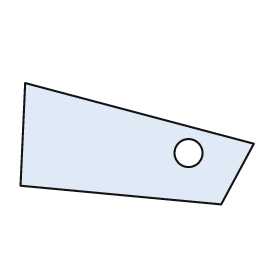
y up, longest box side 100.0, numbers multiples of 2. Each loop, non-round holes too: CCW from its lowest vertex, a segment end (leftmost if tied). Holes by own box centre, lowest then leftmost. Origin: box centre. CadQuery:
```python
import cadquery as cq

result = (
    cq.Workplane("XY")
    .moveTo(36.0, -26.0)
    .lineTo(50.0, 0.0)
    .lineTo(-48.0, 26.0)
    .lineTo(-50.0, -18.0)
    .close()
    .moveTo(22.0, -4.0)
    .circle(6.0)
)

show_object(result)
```